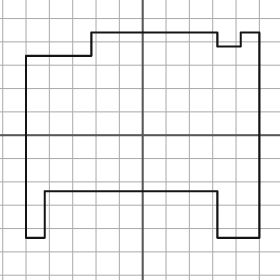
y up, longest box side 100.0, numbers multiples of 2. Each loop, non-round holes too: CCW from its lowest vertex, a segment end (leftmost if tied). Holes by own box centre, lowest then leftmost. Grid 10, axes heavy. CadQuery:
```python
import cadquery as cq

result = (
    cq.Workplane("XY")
    .moveTo(-50.0, -44.0)
    .lineTo(-42.0, -44.0)
    .lineTo(-42.0, -24.0)
    .lineTo(32.0, -24.0)
    .lineTo(32.0, -44.0)
    .lineTo(50.0, -44.0)
    .lineTo(50.0, 44.0)
    .lineTo(42.0, 44.0)
    .lineTo(42.0, 38.0)
    .lineTo(32.0, 38.0)
    .lineTo(32.0, 44.0)
    .lineTo(-22.0, 44.0)
    .lineTo(-22.0, 34.0)
    .lineTo(-50.0, 34.0)
    .close()
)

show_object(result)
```